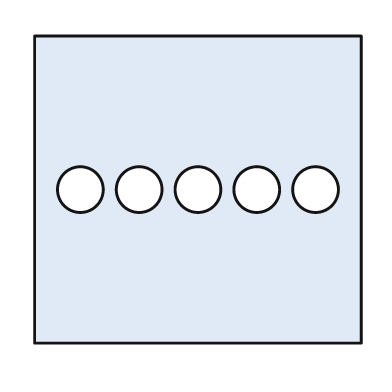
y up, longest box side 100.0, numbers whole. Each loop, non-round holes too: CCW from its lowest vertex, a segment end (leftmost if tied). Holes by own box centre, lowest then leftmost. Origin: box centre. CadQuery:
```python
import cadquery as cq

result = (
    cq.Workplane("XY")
    .moveTo(-50.0, -47.0)
    .lineTo(50.0, -47.0)
    .lineTo(50.0, 47.0)
    .lineTo(-50.0, 47.0)
    .close()
    .moveTo(-36.0, 0.0)
    .circle(7.0)
    .moveTo(-18.0, 0.0)
    .circle(7.0)
    .moveTo(0.0, 0.0)
    .circle(7.0)
    .moveTo(18.0, 0.0)
    .circle(7.0)
    .moveTo(36.0, 0.0)
    .circle(7.0)
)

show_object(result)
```